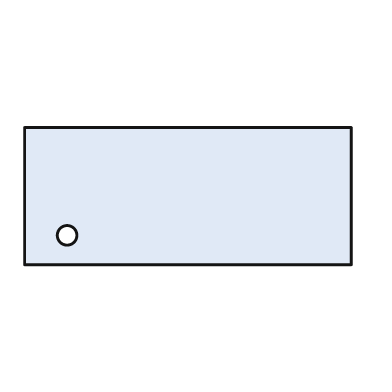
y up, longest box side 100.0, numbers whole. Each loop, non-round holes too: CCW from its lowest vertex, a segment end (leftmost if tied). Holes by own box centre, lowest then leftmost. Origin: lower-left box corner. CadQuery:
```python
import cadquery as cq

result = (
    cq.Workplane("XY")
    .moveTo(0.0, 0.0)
    .lineTo(100.0, 0.0)
    .lineTo(100.0, 42.0)
    .lineTo(0.0, 42.0)
    .close()
    .moveTo(13.0, 9.0)
    .circle(3.0)
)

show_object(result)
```